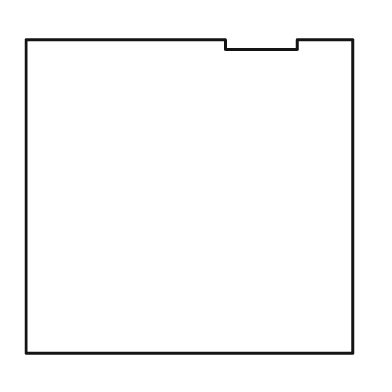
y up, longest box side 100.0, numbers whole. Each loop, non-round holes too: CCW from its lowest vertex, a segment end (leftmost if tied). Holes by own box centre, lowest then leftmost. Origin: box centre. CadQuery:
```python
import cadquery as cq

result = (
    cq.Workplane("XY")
    .moveTo(-50.0, -48.0)
    .lineTo(50.0, -48.0)
    .lineTo(50.0, 48.0)
    .lineTo(33.0, 48.0)
    .lineTo(33.0, 45.0)
    .lineTo(11.0, 45.0)
    .lineTo(11.0, 48.0)
    .lineTo(-50.0, 48.0)
    .close()
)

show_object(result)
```